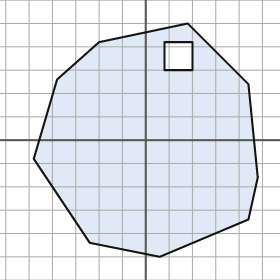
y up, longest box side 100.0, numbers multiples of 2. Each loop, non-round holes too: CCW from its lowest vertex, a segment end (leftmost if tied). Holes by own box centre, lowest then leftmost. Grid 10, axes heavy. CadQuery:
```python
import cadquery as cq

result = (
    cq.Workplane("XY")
    .moveTo(6.0, -50.0)
    .lineTo(44.0, -34.0)
    .lineTo(48.0, -16.0)
    .lineTo(44.0, 24.0)
    .lineTo(18.0, 50.0)
    .lineTo(-20.0, 42.0)
    .lineTo(-38.0, 26.0)
    .lineTo(-48.0, -8.0)
    .lineTo(-24.0, -44.0)
    .close()
    .moveTo(8.0, 30.0)
    .lineTo(20.0, 30.0)
    .lineTo(20.0, 42.0)
    .lineTo(8.0, 42.0)
    .close()
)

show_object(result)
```